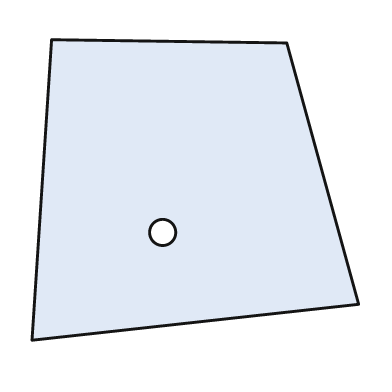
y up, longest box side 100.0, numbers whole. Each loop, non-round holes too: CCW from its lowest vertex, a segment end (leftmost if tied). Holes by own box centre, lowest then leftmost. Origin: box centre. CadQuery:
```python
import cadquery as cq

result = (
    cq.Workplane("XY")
    .moveTo(-50.0, -46.0)
    .lineTo(50.0, -35.0)
    .lineTo(28.0, 45.0)
    .lineTo(-44.0, 46.0)
    .close()
    .moveTo(-10.0, -13.0)
    .circle(4.0)
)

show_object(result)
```